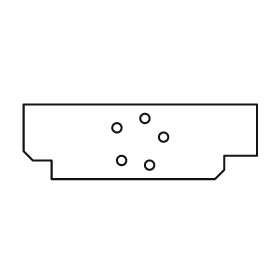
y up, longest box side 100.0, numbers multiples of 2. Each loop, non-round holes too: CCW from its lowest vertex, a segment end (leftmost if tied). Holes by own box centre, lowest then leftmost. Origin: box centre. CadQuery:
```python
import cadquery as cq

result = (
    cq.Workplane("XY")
    .moveTo(-38.0, -16.0)
    .lineTo(32.0, -16.0)
    .lineTo(36.0, -12.0)
    .lineTo(36.0, -6.0)
    .lineTo(50.0, -6.0)
    .lineTo(50.0, 16.0)
    .lineTo(-50.0, 16.0)
    .lineTo(-50.0, -4.0)
    .lineTo(-46.0, -8.0)
    .lineTo(-38.0, -8.0)
    .close()
    .moveTo(4.0, -10.0)
    .circle(2.0)
    .moveTo(-8.0, -8.0)
    .circle(2.0)
    .moveTo(10.0, 2.0)
    .circle(2.0)
    .moveTo(-10.0, 6.0)
    .circle(2.0)
    .moveTo(2.0, 10.0)
    .circle(2.0)
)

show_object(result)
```